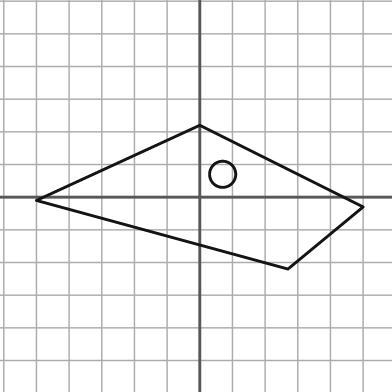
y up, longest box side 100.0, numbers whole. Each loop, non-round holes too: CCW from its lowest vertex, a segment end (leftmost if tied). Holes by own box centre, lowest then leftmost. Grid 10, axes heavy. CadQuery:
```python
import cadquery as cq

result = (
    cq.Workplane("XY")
    .moveTo(27.0, -22.0)
    .lineTo(50.0, -3.0)
    .lineTo(0.0, 22.0)
    .lineTo(-50.0, -1.0)
    .close()
    .moveTo(7.0, 7.0)
    .circle(4.0)
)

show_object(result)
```